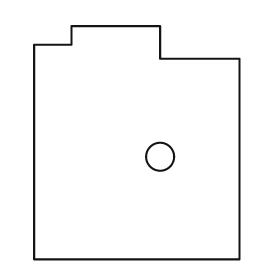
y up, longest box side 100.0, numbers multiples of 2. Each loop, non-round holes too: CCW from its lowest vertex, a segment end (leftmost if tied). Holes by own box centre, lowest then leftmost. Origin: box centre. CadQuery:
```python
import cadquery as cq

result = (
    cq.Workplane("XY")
    .moveTo(-44.0, -50.0)
    .lineTo(44.0, -50.0)
    .lineTo(44.0, 36.0)
    .lineTo(10.0, 36.0)
    .lineTo(10.0, 50.0)
    .lineTo(-28.0, 50.0)
    .lineTo(-28.0, 42.0)
    .lineTo(-44.0, 42.0)
    .close()
    .moveTo(10.0, -6.0)
    .circle(6.0)
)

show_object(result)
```